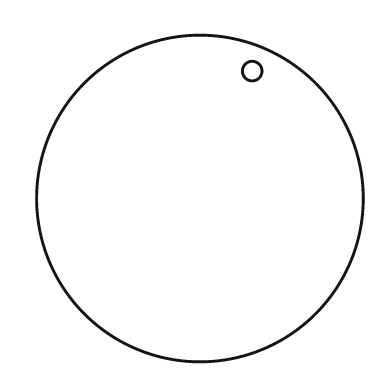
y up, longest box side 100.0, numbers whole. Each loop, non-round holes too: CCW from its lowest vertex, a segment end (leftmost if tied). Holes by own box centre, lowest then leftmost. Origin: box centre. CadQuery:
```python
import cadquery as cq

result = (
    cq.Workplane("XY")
    .moveTo(0.0, 0.0)
    .circle(50.0)
    .moveTo(16.0, 39.0)
    .circle(3.0)
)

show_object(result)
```